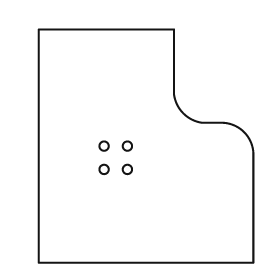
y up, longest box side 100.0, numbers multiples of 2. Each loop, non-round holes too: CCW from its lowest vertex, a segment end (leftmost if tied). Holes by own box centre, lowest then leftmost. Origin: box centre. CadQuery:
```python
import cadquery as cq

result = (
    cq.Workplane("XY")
    .moveTo(-46.0, -50.0)
    .lineTo(46.0, -50.0)
    .lineTo(46.0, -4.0)
    .threePointArc((42.0, 6.0), (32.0, 10.0))
    .lineTo(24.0, 10.0)
    .threePointArc((16.0, 14.0), (12.0, 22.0))
    .lineTo(12.0, 50.0)
    .lineTo(-46.0, 50.0)
    .close()
    .moveTo(-18.0, -10.0)
    .circle(2.0)
    .moveTo(-8.0, -10.0)
    .circle(2.0)
    .moveTo(-18.0, 0.0)
    .circle(2.0)
    .moveTo(-8.0, 0.0)
    .circle(2.0)
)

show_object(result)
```